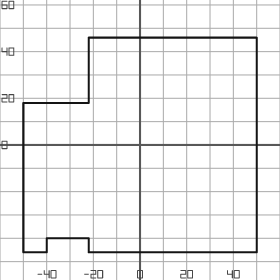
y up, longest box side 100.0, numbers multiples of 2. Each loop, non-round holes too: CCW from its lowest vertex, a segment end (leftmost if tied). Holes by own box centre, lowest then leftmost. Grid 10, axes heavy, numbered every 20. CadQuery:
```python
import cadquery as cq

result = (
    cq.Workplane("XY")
    .moveTo(-50.0, -46.0)
    .lineTo(-40.0, -46.0)
    .lineTo(-40.0, -40.0)
    .lineTo(-22.0, -40.0)
    .lineTo(-22.0, -46.0)
    .lineTo(50.0, -46.0)
    .lineTo(50.0, 46.0)
    .lineTo(-22.0, 46.0)
    .lineTo(-22.0, 18.0)
    .lineTo(-50.0, 18.0)
    .close()
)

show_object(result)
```